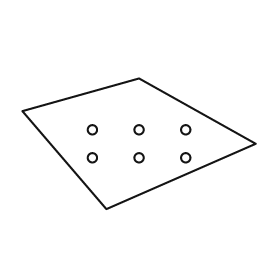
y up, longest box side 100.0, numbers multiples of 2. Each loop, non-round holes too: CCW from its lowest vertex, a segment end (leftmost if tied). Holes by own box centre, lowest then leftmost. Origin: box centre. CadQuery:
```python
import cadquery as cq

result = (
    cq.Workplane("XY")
    .moveTo(-14.0, -28.0)
    .lineTo(50.0, 0.0)
    .lineTo(0.0, 28.0)
    .lineTo(-50.0, 14.0)
    .close()
    .moveTo(-20.0, -6.0)
    .circle(2.0)
    .moveTo(0.0, -6.0)
    .circle(2.0)
    .moveTo(20.0, -6.0)
    .circle(2.0)
    .moveTo(-20.0, 6.0)
    .circle(2.0)
    .moveTo(0.0, 6.0)
    .circle(2.0)
    .moveTo(20.0, 6.0)
    .circle(2.0)
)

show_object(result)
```